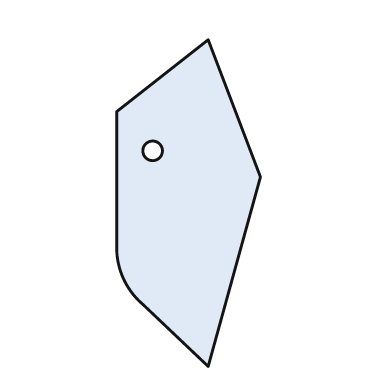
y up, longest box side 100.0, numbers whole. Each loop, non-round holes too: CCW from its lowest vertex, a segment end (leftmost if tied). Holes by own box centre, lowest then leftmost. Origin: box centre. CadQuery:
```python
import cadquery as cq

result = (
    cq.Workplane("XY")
    .moveTo(6.0, -50.0)
    .lineTo(22.0, 8.0)
    .lineTo(6.0, 50.0)
    .lineTo(-22.0, 28.0)
    .lineTo(-22.0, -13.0)
    .threePointArc((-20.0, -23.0), (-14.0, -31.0))
    .close()
    .moveTo(-11.0, 16.0)
    .circle(3.0)
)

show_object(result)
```